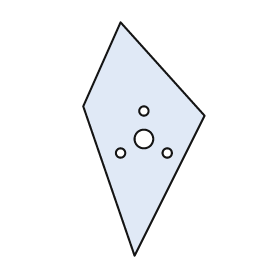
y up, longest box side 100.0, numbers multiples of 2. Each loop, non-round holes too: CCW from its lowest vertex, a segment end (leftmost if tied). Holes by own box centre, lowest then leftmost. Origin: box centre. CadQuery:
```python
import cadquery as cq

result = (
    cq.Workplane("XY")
    .moveTo(-4.0, -50.0)
    .lineTo(26.0, 10.0)
    .lineTo(-10.0, 50.0)
    .lineTo(-26.0, 14.0)
    .close()
    .moveTo(-10.0, -6.0)
    .circle(2.0)
    .moveTo(10.0, -6.0)
    .circle(2.0)
    .moveTo(0.0, 0.0)
    .circle(4.0)
    .moveTo(0.0, 12.0)
    .circle(2.0)
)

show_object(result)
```